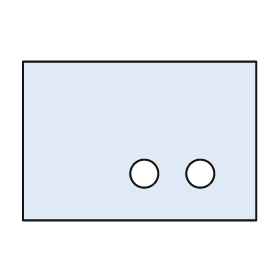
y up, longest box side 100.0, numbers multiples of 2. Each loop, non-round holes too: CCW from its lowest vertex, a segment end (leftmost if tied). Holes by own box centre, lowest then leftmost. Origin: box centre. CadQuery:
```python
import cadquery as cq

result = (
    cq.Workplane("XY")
    .moveTo(-50.0, -34.0)
    .lineTo(50.0, -34.0)
    .lineTo(50.0, 34.0)
    .lineTo(-50.0, 34.0)
    .close()
    .moveTo(2.0, -14.0)
    .circle(6.0)
    .moveTo(26.0, -14.0)
    .circle(6.0)
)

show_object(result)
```